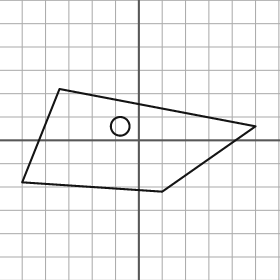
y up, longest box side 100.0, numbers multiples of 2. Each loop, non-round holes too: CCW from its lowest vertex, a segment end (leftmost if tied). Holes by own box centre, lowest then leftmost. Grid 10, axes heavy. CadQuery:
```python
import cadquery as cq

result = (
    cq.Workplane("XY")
    .moveTo(10.0, -22.0)
    .lineTo(50.0, 6.0)
    .lineTo(-34.0, 22.0)
    .lineTo(-50.0, -18.0)
    .close()
    .moveTo(-8.0, 6.0)
    .circle(4.0)
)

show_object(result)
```